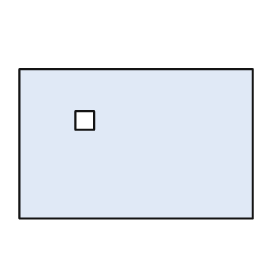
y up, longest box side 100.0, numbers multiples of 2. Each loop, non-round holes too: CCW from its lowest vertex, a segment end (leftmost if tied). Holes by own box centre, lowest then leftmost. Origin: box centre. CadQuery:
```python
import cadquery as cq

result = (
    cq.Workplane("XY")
    .moveTo(-50.0, -32.0)
    .lineTo(50.0, -32.0)
    .lineTo(50.0, 32.0)
    .lineTo(-50.0, 32.0)
    .close()
    .moveTo(-26.0, 6.0)
    .lineTo(-18.0, 6.0)
    .lineTo(-18.0, 14.0)
    .lineTo(-26.0, 14.0)
    .close()
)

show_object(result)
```